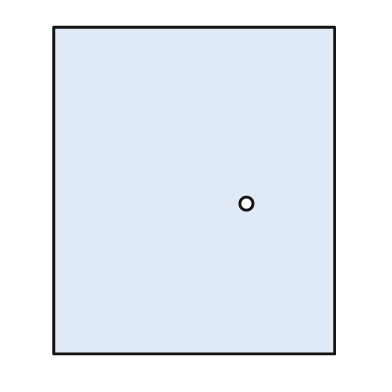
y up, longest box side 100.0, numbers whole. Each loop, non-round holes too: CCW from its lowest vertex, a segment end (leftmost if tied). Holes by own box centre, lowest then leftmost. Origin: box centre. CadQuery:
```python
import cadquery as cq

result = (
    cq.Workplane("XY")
    .moveTo(-43.0, -50.0)
    .lineTo(43.0, -50.0)
    .lineTo(43.0, 50.0)
    .lineTo(-43.0, 50.0)
    .close()
    .moveTo(16.0, -4.0)
    .circle(2.0)
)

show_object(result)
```